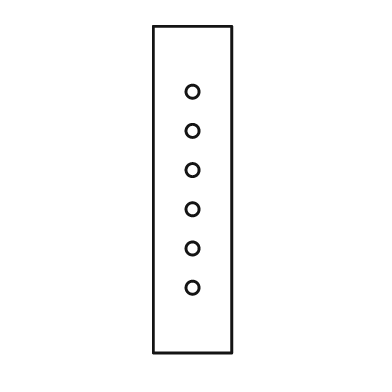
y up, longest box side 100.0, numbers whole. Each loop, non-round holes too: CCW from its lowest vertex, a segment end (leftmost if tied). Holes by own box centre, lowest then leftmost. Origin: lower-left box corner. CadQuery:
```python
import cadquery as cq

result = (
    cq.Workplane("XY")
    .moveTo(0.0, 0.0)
    .lineTo(24.0, 0.0)
    .lineTo(24.0, 100.0)
    .lineTo(0.0, 100.0)
    .close()
    .moveTo(12.0, 20.0)
    .circle(2.0)
    .moveTo(12.0, 32.0)
    .circle(2.0)
    .moveTo(12.0, 44.0)
    .circle(2.0)
    .moveTo(12.0, 56.0)
    .circle(2.0)
    .moveTo(12.0, 68.0)
    .circle(2.0)
    .moveTo(12.0, 80.0)
    .circle(2.0)
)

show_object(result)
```